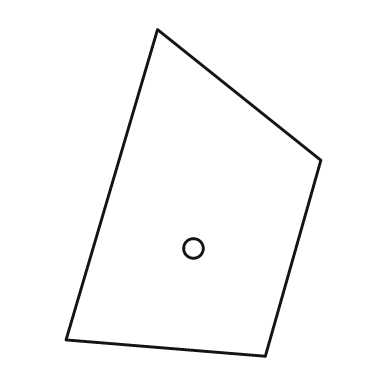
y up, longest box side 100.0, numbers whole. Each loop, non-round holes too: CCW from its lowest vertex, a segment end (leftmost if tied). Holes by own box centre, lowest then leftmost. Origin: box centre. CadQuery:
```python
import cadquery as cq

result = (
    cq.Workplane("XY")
    .moveTo(22.0, -50.0)
    .lineTo(39.0, 10.0)
    .lineTo(-11.0, 50.0)
    .lineTo(-39.0, -45.0)
    .close()
    .moveTo(0.0, -17.0)
    .circle(3.0)
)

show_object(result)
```